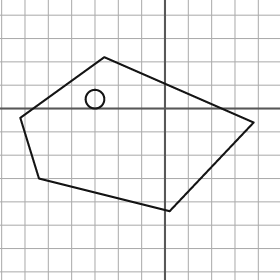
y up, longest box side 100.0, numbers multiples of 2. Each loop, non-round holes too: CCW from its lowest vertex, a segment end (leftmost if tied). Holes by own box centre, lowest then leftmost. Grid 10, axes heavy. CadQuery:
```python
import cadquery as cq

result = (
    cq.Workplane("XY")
    .moveTo(2.0, -44.0)
    .lineTo(38.0, -6.0)
    .lineTo(-26.0, 22.0)
    .lineTo(-62.0, -4.0)
    .lineTo(-54.0, -30.0)
    .close()
    .moveTo(-30.0, 4.0)
    .circle(4.0)
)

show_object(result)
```